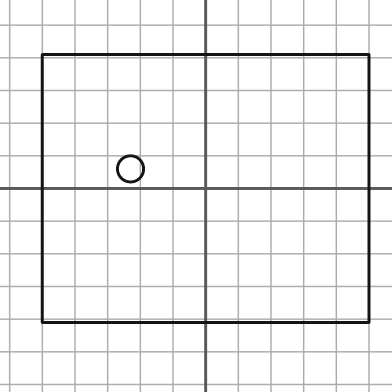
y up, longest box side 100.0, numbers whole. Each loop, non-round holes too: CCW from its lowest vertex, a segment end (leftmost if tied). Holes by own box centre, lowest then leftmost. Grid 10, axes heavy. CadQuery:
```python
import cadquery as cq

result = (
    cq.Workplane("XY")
    .moveTo(-50.0, -41.0)
    .lineTo(50.0, -41.0)
    .lineTo(50.0, 41.0)
    .lineTo(-50.0, 41.0)
    .close()
    .moveTo(-23.0, 6.0)
    .circle(4.0)
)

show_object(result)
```